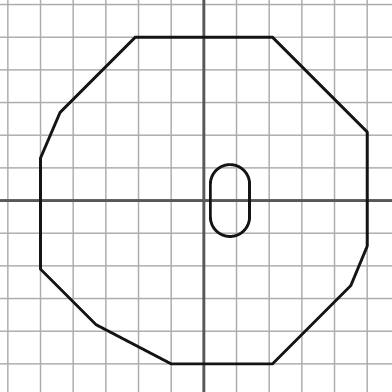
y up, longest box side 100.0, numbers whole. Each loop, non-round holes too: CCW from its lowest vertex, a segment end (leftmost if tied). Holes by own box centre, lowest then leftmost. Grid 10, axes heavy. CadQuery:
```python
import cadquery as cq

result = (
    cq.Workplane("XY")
    .moveTo(-10.0, -50.0)
    .lineTo(21.0, -50.0)
    .lineTo(45.0, -26.0)
    .lineTo(50.0, -14.0)
    .lineTo(50.0, 21.0)
    .lineTo(21.0, 50.0)
    .lineTo(-21.0, 50.0)
    .lineTo(-44.0, 27.0)
    .lineTo(-50.0, 13.0)
    .lineTo(-50.0, -21.0)
    .lineTo(-33.0, -38.0)
    .close()
    .moveTo(2.0, -5.0)
    .threePointArc((8.0, -11.0), (14.0, -5.0))
    .lineTo(14.0, 5.0)
    .threePointArc((8.0, 11.0), (2.0, 5.0))
    .close()
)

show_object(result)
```